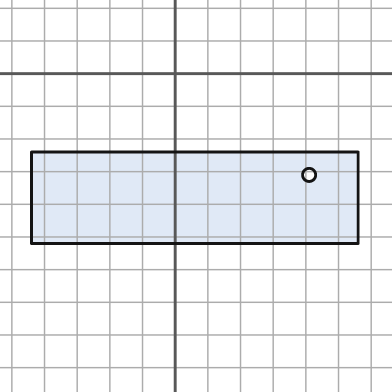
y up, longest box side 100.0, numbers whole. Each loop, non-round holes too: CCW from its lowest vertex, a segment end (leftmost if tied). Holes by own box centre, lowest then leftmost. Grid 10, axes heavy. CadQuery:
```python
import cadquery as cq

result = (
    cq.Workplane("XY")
    .moveTo(-44.0, -52.0)
    .lineTo(56.0, -52.0)
    .lineTo(56.0, -24.0)
    .lineTo(-44.0, -24.0)
    .close()
    .moveTo(41.0, -31.0)
    .circle(2.0)
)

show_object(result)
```